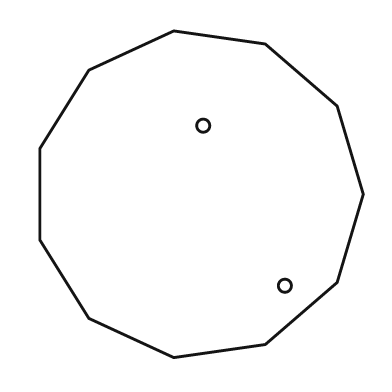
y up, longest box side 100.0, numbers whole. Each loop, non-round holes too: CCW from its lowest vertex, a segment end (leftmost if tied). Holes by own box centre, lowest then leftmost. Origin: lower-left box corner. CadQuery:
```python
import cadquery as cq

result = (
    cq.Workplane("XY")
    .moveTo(41.0, 0.0)
    .lineTo(69.0, 4.0)
    .lineTo(91.0, 23.0)
    .lineTo(99.0, 50.0)
    .lineTo(91.0, 77.0)
    .lineTo(69.0, 96.0)
    .lineTo(41.0, 100.0)
    .lineTo(15.0, 88.0)
    .lineTo(0.0, 64.0)
    .lineTo(0.0, 36.0)
    .lineTo(15.0, 12.0)
    .close()
    .moveTo(75.0, 22.0)
    .circle(2.0)
    .moveTo(50.0, 71.0)
    .circle(2.0)
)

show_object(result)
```